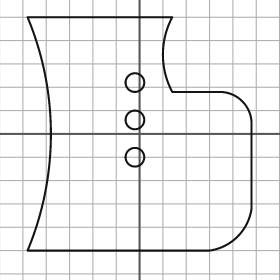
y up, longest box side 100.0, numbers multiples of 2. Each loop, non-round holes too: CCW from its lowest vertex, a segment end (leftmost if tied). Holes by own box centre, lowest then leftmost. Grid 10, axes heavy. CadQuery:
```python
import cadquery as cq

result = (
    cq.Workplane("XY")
    .moveTo(-48.0, -50.0)
    .lineTo(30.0, -50.0)
    .threePointArc((42.0, -44.0), (48.0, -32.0))
    .lineTo(48.0, 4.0)
    .threePointArc((44.0, 14.0), (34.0, 18.0))
    .lineTo(14.0, 18.0)
    .threePointArc((10.0, 34.0), (14.0, 50.0))
    .lineTo(-48.0, 50.0)
    .threePointArc((-38.0, 0.0), (-48.0, -50.0))
    .close()
    .moveTo(-2.0, -10.0)
    .circle(4.0)
    .moveTo(-2.0, 6.0)
    .circle(4.0)
    .moveTo(-2.0, 22.0)
    .circle(4.0)
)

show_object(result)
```